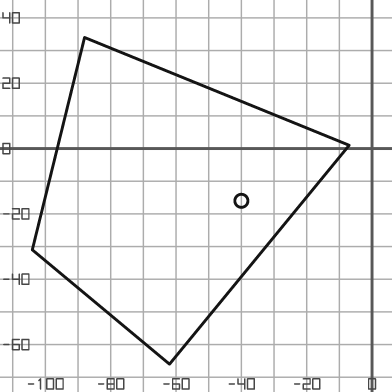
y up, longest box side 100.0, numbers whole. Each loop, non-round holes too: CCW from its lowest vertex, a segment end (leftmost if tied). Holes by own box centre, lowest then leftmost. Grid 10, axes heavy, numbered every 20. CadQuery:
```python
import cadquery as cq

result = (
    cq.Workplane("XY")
    .moveTo(-62.0, -66.0)
    .lineTo(-7.0, 1.0)
    .lineTo(-88.0, 34.0)
    .lineTo(-104.0, -31.0)
    .close()
    .moveTo(-40.0, -16.0)
    .circle(2.0)
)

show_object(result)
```